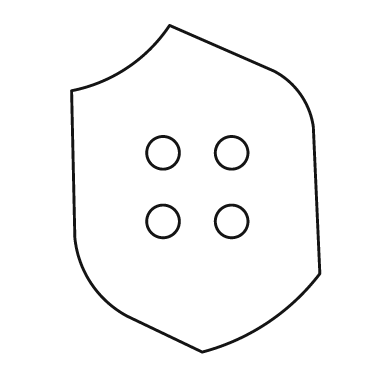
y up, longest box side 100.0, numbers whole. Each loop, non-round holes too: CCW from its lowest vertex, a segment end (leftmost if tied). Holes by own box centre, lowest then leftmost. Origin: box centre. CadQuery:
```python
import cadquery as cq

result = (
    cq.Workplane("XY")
    .moveTo(2.0, -50.0)
    .threePointArc((22.0, -41.0), (38.0, -26.0))
    .lineTo(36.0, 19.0)
    .threePointArc((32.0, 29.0), (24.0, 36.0))
    .lineTo(-8.0, 50.0)
    .threePointArc((-21.0, 37.0), (-38.0, 30.0))
    .lineTo(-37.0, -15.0)
    .threePointArc((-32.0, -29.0), (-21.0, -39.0))
    .close()
    .moveTo(-10.0, -10.0)
    .circle(5.0)
    .moveTo(11.0, -10.0)
    .circle(5.0)
    .moveTo(-10.0, 11.0)
    .circle(5.0)
    .moveTo(11.0, 11.0)
    .circle(5.0)
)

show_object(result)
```